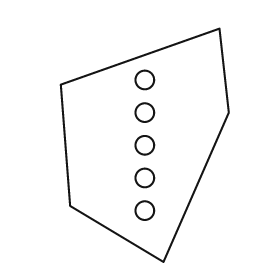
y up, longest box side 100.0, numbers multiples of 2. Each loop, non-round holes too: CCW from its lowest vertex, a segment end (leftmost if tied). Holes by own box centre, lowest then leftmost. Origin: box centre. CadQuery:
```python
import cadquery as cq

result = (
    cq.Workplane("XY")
    .moveTo(8.0, -50.0)
    .lineTo(36.0, 14.0)
    .lineTo(32.0, 50.0)
    .lineTo(-36.0, 26.0)
    .lineTo(-32.0, -26.0)
    .close()
    .moveTo(0.0, -28.0)
    .circle(4.0)
    .moveTo(0.0, -14.0)
    .circle(4.0)
    .moveTo(0.0, 0.0)
    .circle(4.0)
    .moveTo(0.0, 14.0)
    .circle(4.0)
    .moveTo(0.0, 28.0)
    .circle(4.0)
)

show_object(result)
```